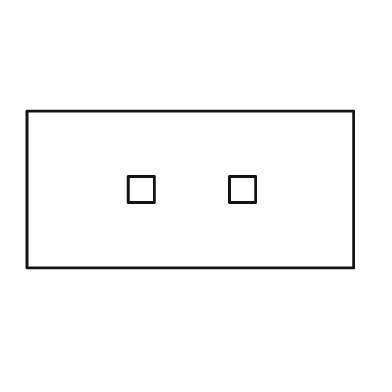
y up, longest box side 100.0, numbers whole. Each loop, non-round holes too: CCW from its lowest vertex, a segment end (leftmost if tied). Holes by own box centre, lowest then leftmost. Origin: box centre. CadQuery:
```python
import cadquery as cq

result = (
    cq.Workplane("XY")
    .moveTo(-50.0, -24.0)
    .lineTo(50.0, -24.0)
    .lineTo(50.0, 24.0)
    .lineTo(-50.0, 24.0)
    .close()
    .moveTo(-19.0, -4.0)
    .lineTo(-11.0, -4.0)
    .lineTo(-11.0, 4.0)
    .lineTo(-19.0, 4.0)
    .close()
    .moveTo(12.0, -4.0)
    .lineTo(20.0, -4.0)
    .lineTo(20.0, 4.0)
    .lineTo(12.0, 4.0)
    .close()
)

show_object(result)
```